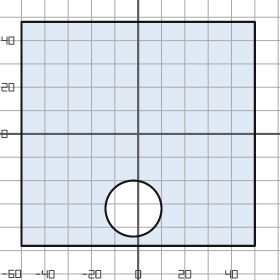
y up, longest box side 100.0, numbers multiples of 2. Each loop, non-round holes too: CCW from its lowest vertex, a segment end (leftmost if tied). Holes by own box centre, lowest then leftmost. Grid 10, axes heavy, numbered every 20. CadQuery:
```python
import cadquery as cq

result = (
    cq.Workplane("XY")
    .moveTo(-50.0, -48.0)
    .lineTo(50.0, -48.0)
    .lineTo(50.0, 48.0)
    .lineTo(-50.0, 48.0)
    .close()
    .moveTo(-2.0, -32.0)
    .circle(12.0)
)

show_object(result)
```